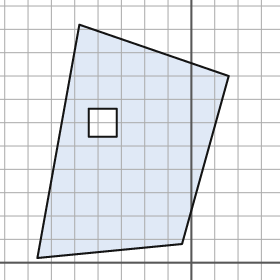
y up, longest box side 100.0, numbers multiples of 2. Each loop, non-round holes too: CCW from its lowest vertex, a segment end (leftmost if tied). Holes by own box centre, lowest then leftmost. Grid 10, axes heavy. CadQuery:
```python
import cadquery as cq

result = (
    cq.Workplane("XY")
    .moveTo(-66.0, 2.0)
    .lineTo(-4.0, 8.0)
    .lineTo(16.0, 80.0)
    .lineTo(-48.0, 102.0)
    .close()
    .moveTo(-44.0, 54.0)
    .lineTo(-32.0, 54.0)
    .lineTo(-32.0, 66.0)
    .lineTo(-44.0, 66.0)
    .close()
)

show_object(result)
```